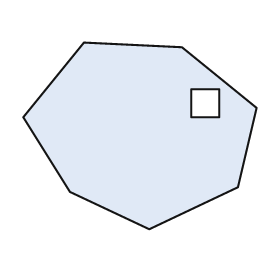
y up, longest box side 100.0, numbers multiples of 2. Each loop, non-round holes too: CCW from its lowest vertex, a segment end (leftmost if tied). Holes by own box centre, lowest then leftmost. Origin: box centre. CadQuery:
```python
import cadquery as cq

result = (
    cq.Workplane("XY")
    .moveTo(4.0, -40.0)
    .lineTo(42.0, -22.0)
    .lineTo(50.0, 12.0)
    .lineTo(18.0, 38.0)
    .lineTo(-24.0, 40.0)
    .lineTo(-50.0, 8.0)
    .lineTo(-30.0, -24.0)
    .close()
    .moveTo(22.0, 8.0)
    .lineTo(34.0, 8.0)
    .lineTo(34.0, 20.0)
    .lineTo(22.0, 20.0)
    .close()
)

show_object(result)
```